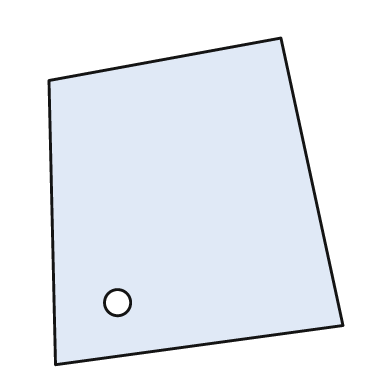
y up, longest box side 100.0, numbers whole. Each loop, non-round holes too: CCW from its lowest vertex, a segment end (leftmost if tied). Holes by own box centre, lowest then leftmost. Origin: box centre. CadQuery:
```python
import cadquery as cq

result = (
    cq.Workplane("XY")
    .moveTo(-43.0, -50.0)
    .lineTo(45.0, -38.0)
    .lineTo(26.0, 50.0)
    .lineTo(-45.0, 37.0)
    .close()
    .moveTo(-24.0, -31.0)
    .circle(4.0)
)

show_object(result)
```